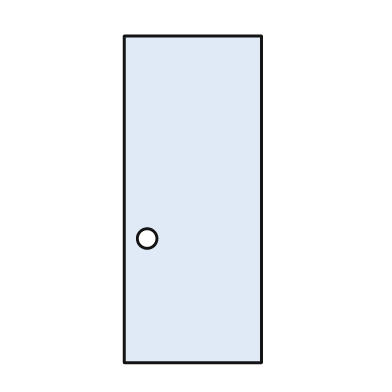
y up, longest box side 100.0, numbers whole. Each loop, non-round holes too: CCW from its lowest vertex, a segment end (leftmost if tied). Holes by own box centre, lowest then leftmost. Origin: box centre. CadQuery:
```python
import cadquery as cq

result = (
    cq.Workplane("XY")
    .moveTo(-21.0, -50.0)
    .lineTo(21.0, -50.0)
    .lineTo(21.0, 50.0)
    .lineTo(-21.0, 50.0)
    .close()
    .moveTo(-14.0, -12.0)
    .circle(3.0)
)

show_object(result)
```